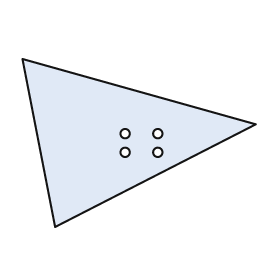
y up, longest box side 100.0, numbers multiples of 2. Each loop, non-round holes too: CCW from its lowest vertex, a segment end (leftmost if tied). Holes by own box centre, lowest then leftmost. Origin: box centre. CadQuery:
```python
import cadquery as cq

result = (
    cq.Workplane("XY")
    .moveTo(-36.0, -36.0)
    .lineTo(50.0, 8.0)
    .lineTo(-50.0, 36.0)
    .close()
    .moveTo(-6.0, -4.0)
    .circle(2.0)
    .moveTo(8.0, -4.0)
    .circle(2.0)
    .moveTo(-6.0, 4.0)
    .circle(2.0)
    .moveTo(8.0, 4.0)
    .circle(2.0)
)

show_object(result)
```